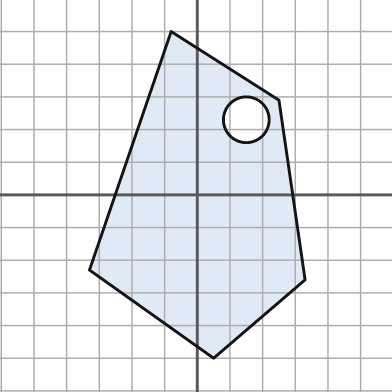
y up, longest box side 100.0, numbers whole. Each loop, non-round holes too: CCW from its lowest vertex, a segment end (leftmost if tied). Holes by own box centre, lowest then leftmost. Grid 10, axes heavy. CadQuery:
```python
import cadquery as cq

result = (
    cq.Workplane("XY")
    .moveTo(5.0, -50.0)
    .lineTo(33.0, -26.0)
    .lineTo(25.0, 29.0)
    .lineTo(-8.0, 50.0)
    .lineTo(-33.0, -23.0)
    .close()
    .moveTo(15.0, 23.0)
    .circle(7.0)
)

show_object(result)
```